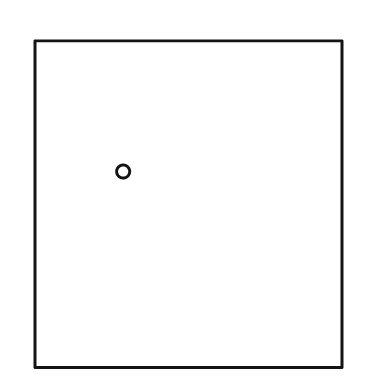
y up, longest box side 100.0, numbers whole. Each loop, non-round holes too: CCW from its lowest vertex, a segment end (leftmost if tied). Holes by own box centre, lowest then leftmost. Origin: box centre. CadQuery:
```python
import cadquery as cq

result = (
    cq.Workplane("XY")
    .moveTo(-47.0, -50.0)
    .lineTo(47.0, -50.0)
    .lineTo(47.0, 50.0)
    .lineTo(-47.0, 50.0)
    .close()
    .moveTo(-20.0, 10.0)
    .circle(2.0)
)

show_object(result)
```